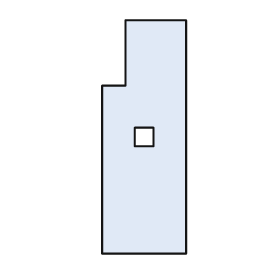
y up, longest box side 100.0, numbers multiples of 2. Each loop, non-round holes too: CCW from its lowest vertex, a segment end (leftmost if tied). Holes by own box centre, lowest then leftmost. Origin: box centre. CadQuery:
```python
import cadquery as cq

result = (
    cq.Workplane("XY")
    .moveTo(-18.0, -50.0)
    .lineTo(18.0, -50.0)
    .lineTo(18.0, 50.0)
    .lineTo(-8.0, 50.0)
    .lineTo(-8.0, 22.0)
    .lineTo(-18.0, 22.0)
    .close()
    .moveTo(-4.0, -4.0)
    .lineTo(4.0, -4.0)
    .lineTo(4.0, 4.0)
    .lineTo(-4.0, 4.0)
    .close()
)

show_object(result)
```